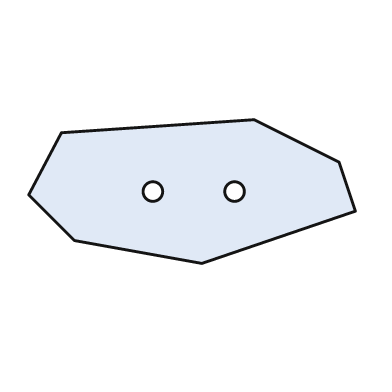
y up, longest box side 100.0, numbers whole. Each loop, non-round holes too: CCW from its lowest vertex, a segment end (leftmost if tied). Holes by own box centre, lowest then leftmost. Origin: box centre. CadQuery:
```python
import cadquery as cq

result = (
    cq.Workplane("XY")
    .moveTo(3.0, -22.0)
    .lineTo(50.0, -6.0)
    .lineTo(45.0, 9.0)
    .lineTo(19.0, 22.0)
    .lineTo(-40.0, 18.0)
    .lineTo(-50.0, -1.0)
    .lineTo(-36.0, -15.0)
    .close()
    .moveTo(-12.0, 0.0)
    .circle(3.0)
    .moveTo(13.0, 0.0)
    .circle(3.0)
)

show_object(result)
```